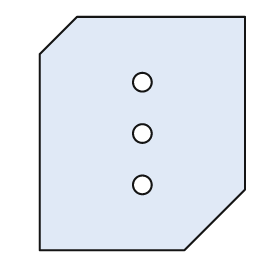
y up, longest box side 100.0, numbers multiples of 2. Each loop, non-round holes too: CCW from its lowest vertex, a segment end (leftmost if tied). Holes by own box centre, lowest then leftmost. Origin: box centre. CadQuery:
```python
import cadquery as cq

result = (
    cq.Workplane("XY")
    .moveTo(-44.0, -50.0)
    .lineTo(18.0, -50.0)
    .lineTo(44.0, -24.0)
    .lineTo(44.0, 50.0)
    .lineTo(-28.0, 50.0)
    .lineTo(-44.0, 34.0)
    .close()
    .moveTo(0.0, -22.0)
    .circle(4.0)
    .moveTo(0.0, 0.0)
    .circle(4.0)
    .moveTo(0.0, 22.0)
    .circle(4.0)
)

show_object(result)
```